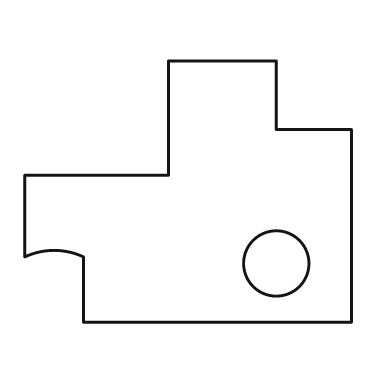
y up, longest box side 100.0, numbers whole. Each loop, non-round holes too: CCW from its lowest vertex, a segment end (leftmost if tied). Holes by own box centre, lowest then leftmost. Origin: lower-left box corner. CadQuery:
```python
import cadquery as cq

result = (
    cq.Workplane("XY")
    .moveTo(18.0, 0.0)
    .lineTo(100.0, 0.0)
    .lineTo(100.0, 59.0)
    .lineTo(77.0, 59.0)
    .lineTo(77.0, 80.0)
    .lineTo(44.0, 80.0)
    .lineTo(44.0, 45.0)
    .lineTo(0.0, 45.0)
    .lineTo(0.0, 20.0)
    .threePointArc((9.0, 22.0), (18.0, 20.0))
    .close()
    .moveTo(77.0, 18.0)
    .circle(10.0)
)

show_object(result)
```